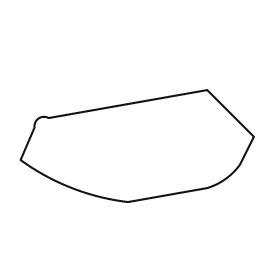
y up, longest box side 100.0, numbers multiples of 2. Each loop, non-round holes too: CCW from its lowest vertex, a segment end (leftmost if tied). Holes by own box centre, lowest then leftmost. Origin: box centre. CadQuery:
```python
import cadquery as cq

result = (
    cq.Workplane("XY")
    .moveTo(-4.0, -24.0)
    .lineTo(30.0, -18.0)
    .threePointArc((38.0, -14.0), (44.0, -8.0))
    .lineTo(50.0, 4.0)
    .lineTo(30.0, 24.0)
    .lineTo(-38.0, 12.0)
    .threePointArc((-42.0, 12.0), (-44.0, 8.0))
    .lineTo(-50.0, -6.0)
    .threePointArc((-28.0, -18.0), (-4.0, -24.0))
    .close()
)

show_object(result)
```